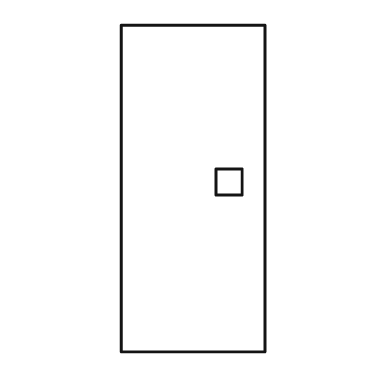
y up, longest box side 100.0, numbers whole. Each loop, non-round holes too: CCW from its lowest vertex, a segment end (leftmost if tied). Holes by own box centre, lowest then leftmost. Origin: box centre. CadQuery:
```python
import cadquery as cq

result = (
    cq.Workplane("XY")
    .moveTo(-22.0, -50.0)
    .lineTo(22.0, -50.0)
    .lineTo(22.0, 50.0)
    .lineTo(-22.0, 50.0)
    .close()
    .moveTo(7.0, -2.0)
    .lineTo(15.0, -2.0)
    .lineTo(15.0, 6.0)
    .lineTo(7.0, 6.0)
    .close()
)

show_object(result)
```